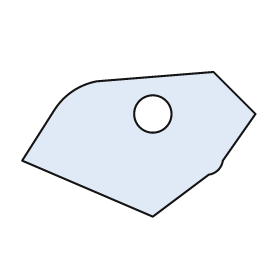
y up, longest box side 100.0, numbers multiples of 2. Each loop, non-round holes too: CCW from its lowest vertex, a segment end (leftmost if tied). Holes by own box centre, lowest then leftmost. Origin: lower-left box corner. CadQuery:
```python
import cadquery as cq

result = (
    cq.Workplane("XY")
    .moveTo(56.0, 0.0)
    .lineTo(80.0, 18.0)
    .threePointArc((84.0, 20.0), (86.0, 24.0))
    .lineTo(100.0, 44.0)
    .lineTo(82.0, 62.0)
    .lineTo(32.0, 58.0)
    .threePointArc((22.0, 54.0), (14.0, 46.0))
    .lineTo(0.0, 24.0)
    .close()
    .moveTo(56.0, 44.0)
    .circle(8.0)
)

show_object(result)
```